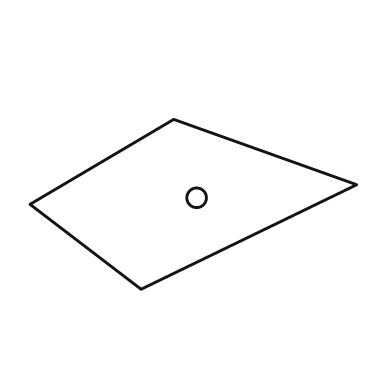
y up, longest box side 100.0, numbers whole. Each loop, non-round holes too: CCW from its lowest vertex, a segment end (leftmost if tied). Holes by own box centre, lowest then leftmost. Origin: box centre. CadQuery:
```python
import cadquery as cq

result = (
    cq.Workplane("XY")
    .moveTo(-16.0, -26.0)
    .lineTo(50.0, 6.0)
    .lineTo(-6.0, 26.0)
    .lineTo(-50.0, 0.0)
    .close()
    .moveTo(1.0, 2.0)
    .circle(3.0)
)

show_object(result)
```